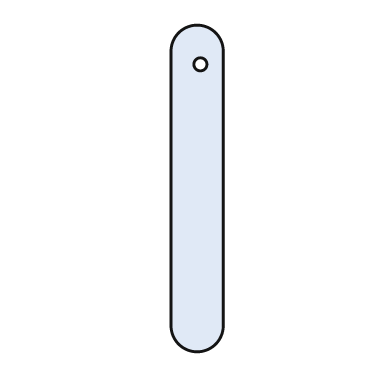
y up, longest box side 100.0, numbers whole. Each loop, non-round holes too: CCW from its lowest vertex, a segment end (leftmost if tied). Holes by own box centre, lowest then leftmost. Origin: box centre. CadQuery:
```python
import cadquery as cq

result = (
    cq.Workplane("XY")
    .moveTo(-8.0, -42.0)
    .threePointArc((0.0, -50.0), (8.0, -42.0))
    .lineTo(8.0, 42.0)
    .threePointArc((0.0, 50.0), (-8.0, 42.0))
    .close()
    .moveTo(1.0, 38.0)
    .circle(2.0)
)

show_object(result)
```